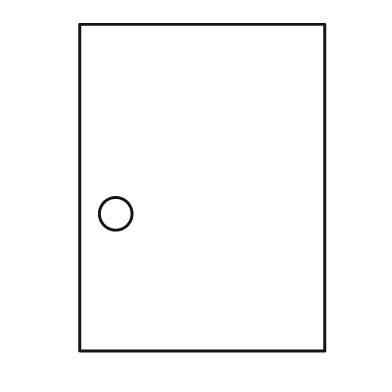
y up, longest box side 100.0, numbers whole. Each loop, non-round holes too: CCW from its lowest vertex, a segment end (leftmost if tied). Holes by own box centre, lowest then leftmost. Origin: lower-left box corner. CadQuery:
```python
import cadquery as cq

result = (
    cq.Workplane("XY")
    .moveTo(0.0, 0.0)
    .lineTo(75.0, 0.0)
    .lineTo(75.0, 100.0)
    .lineTo(0.0, 100.0)
    .close()
    .moveTo(11.0, 42.0)
    .circle(5.0)
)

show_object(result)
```